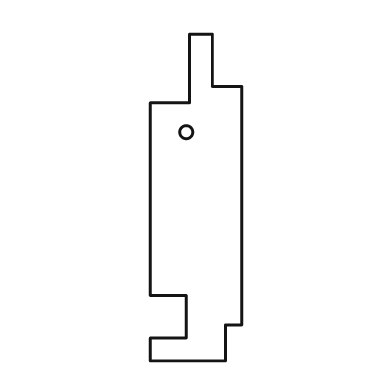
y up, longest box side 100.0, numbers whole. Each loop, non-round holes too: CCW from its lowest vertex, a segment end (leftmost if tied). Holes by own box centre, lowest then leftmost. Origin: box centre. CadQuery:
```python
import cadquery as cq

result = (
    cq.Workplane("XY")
    .moveTo(-14.0, -50.0)
    .lineTo(9.0, -50.0)
    .lineTo(9.0, -39.0)
    .lineTo(14.0, -39.0)
    .lineTo(14.0, 34.0)
    .lineTo(5.0, 34.0)
    .lineTo(5.0, 50.0)
    .lineTo(-2.0, 50.0)
    .lineTo(-2.0, 29.0)
    .lineTo(-14.0, 29.0)
    .lineTo(-14.0, -30.0)
    .lineTo(-3.0, -30.0)
    .lineTo(-3.0, -43.0)
    .lineTo(-14.0, -43.0)
    .close()
    .moveTo(-3.0, 20.0)
    .circle(2.0)
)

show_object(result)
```